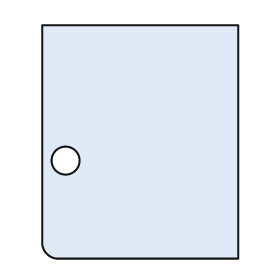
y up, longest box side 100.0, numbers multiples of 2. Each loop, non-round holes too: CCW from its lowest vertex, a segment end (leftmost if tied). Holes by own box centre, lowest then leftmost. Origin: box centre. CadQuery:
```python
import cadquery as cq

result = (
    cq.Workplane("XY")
    .moveTo(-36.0, -50.0)
    .lineTo(42.0, -50.0)
    .lineTo(42.0, 50.0)
    .lineTo(-42.0, 50.0)
    .lineTo(-42.0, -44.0)
    .threePointArc((-40.0, -48.0), (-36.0, -50.0))
    .close()
    .moveTo(-32.0, -8.0)
    .circle(6.0)
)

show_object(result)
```